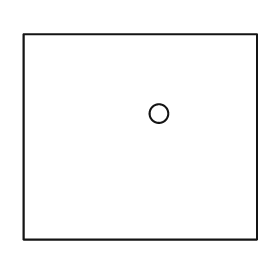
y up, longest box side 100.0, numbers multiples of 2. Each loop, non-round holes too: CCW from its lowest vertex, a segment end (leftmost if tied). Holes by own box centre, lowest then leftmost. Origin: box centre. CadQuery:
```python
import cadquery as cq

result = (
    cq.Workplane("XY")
    .moveTo(-50.0, -44.0)
    .lineTo(50.0, -44.0)
    .lineTo(50.0, 44.0)
    .lineTo(-50.0, 44.0)
    .close()
    .moveTo(8.0, 10.0)
    .circle(4.0)
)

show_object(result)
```